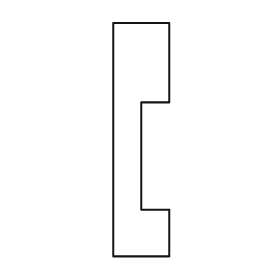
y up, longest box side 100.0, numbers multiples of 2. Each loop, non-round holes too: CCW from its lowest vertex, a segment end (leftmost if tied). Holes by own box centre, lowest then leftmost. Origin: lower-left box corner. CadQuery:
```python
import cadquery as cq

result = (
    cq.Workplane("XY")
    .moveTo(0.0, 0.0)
    .lineTo(24.0, 0.0)
    .lineTo(24.0, 20.0)
    .lineTo(12.0, 20.0)
    .lineTo(12.0, 66.0)
    .lineTo(24.0, 66.0)
    .lineTo(24.0, 100.0)
    .lineTo(0.0, 100.0)
    .close()
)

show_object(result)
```